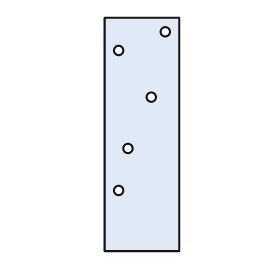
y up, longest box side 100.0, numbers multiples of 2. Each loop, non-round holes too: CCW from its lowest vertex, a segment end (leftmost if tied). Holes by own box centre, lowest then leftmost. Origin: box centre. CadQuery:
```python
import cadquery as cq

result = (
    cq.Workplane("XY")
    .moveTo(-16.0, -50.0)
    .lineTo(16.0, -50.0)
    .lineTo(16.0, 50.0)
    .lineTo(-16.0, 50.0)
    .close()
    .moveTo(-10.0, -24.0)
    .circle(2.0)
    .moveTo(-6.0, -6.0)
    .circle(2.0)
    .moveTo(4.0, 16.0)
    .circle(2.0)
    .moveTo(-10.0, 36.0)
    .circle(2.0)
    .moveTo(10.0, 44.0)
    .circle(2.0)
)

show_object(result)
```